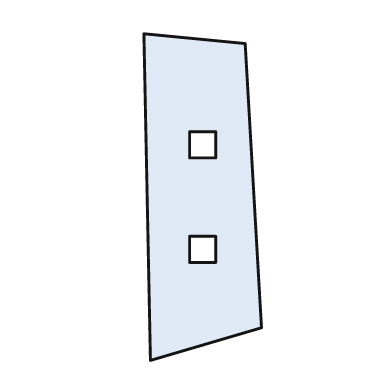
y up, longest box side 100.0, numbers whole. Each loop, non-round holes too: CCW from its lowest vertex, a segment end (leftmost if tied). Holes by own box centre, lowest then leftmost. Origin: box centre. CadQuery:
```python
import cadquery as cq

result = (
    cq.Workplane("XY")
    .moveTo(-16.0, -50.0)
    .lineTo(18.0, -40.0)
    .lineTo(13.0, 47.0)
    .lineTo(-18.0, 50.0)
    .close()
    .moveTo(-4.0, -20.0)
    .lineTo(4.0, -20.0)
    .lineTo(4.0, -12.0)
    .lineTo(-4.0, -12.0)
    .close()
    .moveTo(-4.0, 12.0)
    .lineTo(4.0, 12.0)
    .lineTo(4.0, 20.0)
    .lineTo(-4.0, 20.0)
    .close()
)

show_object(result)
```